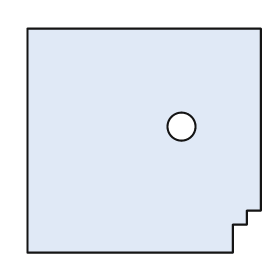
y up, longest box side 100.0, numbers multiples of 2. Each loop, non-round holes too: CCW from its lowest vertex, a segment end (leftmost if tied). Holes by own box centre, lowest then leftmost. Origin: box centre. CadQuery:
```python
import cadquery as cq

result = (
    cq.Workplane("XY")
    .moveTo(-50.0, -48.0)
    .lineTo(38.0, -48.0)
    .lineTo(38.0, -36.0)
    .lineTo(44.0, -36.0)
    .lineTo(44.0, -30.0)
    .lineTo(50.0, -30.0)
    .lineTo(50.0, 48.0)
    .lineTo(-50.0, 48.0)
    .close()
    .moveTo(16.0, 6.0)
    .circle(6.0)
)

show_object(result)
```